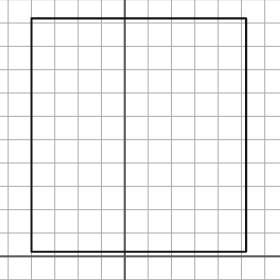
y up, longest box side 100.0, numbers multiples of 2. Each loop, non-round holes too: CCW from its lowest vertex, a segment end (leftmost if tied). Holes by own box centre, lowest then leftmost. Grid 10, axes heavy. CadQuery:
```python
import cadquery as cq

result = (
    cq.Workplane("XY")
    .moveTo(-40.0, 2.0)
    .lineTo(52.0, 2.0)
    .lineTo(52.0, 102.0)
    .lineTo(-40.0, 102.0)
    .close()
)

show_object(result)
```